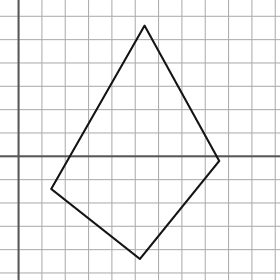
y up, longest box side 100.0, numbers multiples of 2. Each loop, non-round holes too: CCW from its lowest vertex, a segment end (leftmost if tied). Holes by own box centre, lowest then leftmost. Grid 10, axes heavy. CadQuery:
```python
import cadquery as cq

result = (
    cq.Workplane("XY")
    .moveTo(52.0, -44.0)
    .lineTo(86.0, -2.0)
    .lineTo(54.0, 56.0)
    .lineTo(14.0, -14.0)
    .close()
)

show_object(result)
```